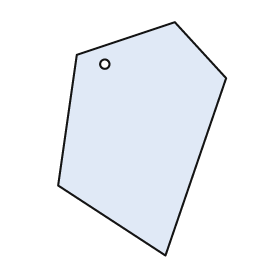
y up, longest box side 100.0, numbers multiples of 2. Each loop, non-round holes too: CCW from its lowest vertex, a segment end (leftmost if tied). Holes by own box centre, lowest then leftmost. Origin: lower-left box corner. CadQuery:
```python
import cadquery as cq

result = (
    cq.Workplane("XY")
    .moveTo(46.0, 0.0)
    .lineTo(72.0, 76.0)
    .lineTo(50.0, 100.0)
    .lineTo(8.0, 86.0)
    .lineTo(0.0, 30.0)
    .close()
    .moveTo(20.0, 82.0)
    .circle(2.0)
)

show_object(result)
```